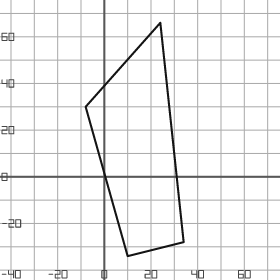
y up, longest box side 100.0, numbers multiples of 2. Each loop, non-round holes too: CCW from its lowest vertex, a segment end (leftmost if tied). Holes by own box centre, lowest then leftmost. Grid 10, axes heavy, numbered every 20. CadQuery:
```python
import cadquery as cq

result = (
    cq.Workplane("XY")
    .moveTo(10.0, -34.0)
    .lineTo(34.0, -28.0)
    .lineTo(24.0, 66.0)
    .lineTo(-8.0, 30.0)
    .close()
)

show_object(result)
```